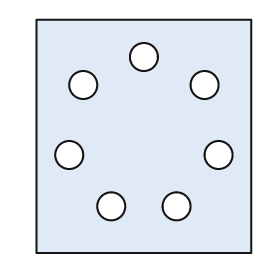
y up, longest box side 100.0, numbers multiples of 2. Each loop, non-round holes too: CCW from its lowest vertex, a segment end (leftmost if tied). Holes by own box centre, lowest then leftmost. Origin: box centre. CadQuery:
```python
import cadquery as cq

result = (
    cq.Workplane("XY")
    .moveTo(-46.0, -50.0)
    .lineTo(46.0, -50.0)
    .lineTo(46.0, 50.0)
    .lineTo(-46.0, 50.0)
    .close()
    .moveTo(-14.0, -30.0)
    .circle(6.0)
    .moveTo(14.0, -30.0)
    .circle(6.0)
    .moveTo(-32.0, -8.0)
    .circle(6.0)
    .moveTo(32.0, -8.0)
    .circle(6.0)
    .moveTo(-26.0, 22.0)
    .circle(6.0)
    .moveTo(26.0, 22.0)
    .circle(6.0)
    .moveTo(0.0, 34.0)
    .circle(6.0)
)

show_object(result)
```